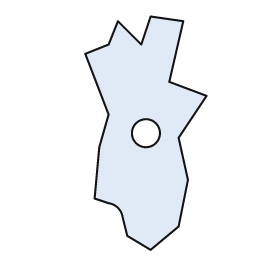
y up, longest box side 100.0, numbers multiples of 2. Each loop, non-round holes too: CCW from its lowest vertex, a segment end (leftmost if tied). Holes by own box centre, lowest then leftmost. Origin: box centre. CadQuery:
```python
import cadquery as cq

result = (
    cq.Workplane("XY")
    .moveTo(2.0, -50.0)
    .lineTo(14.0, -40.0)
    .lineTo(18.0, -20.0)
    .lineTo(14.0, -2.0)
    .lineTo(26.0, 16.0)
    .lineTo(10.0, 22.0)
    .lineTo(16.0, 48.0)
    .lineTo(2.0, 50.0)
    .lineTo(-2.0, 38.0)
    .lineTo(-12.0, 48.0)
    .lineTo(-16.0, 38.0)
    .lineTo(-26.0, 34.0)
    .lineTo(-16.0, 8.0)
    .lineTo(-20.0, -6.0)
    .lineTo(-22.0, -28.0)
    .lineTo(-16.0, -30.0)
    .threePointArc((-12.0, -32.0), (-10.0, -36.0))
    .lineTo(-8.0, -44.0)
    .close()
    .moveTo(0.0, 0.0)
    .circle(6.0)
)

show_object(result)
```